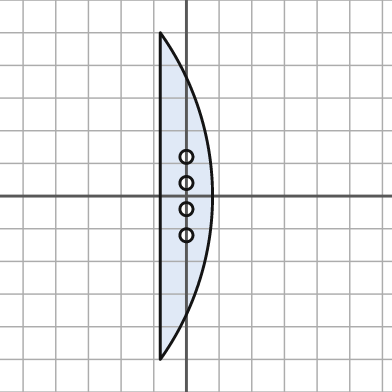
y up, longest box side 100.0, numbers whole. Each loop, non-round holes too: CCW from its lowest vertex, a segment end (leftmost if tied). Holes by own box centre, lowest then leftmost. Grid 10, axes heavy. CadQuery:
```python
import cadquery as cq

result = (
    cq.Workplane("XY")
    .moveTo(-8.0, -50.0)
    .threePointArc((8.0, 0.0), (-8.0, 50.0))
    .close()
    .moveTo(0.0, -12.0)
    .circle(2.0)
    .moveTo(0.0, -4.0)
    .circle(2.0)
    .moveTo(0.0, 4.0)
    .circle(2.0)
    .moveTo(0.0, 12.0)
    .circle(2.0)
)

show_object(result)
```